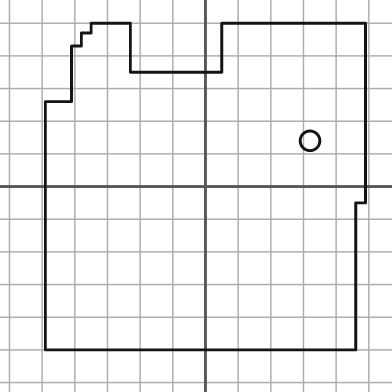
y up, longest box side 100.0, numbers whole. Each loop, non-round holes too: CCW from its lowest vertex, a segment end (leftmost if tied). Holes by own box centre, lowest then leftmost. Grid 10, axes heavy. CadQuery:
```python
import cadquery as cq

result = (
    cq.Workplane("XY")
    .moveTo(-49.0, -50.0)
    .lineTo(46.0, -50.0)
    .lineTo(46.0, -5.0)
    .lineTo(49.0, -5.0)
    .lineTo(49.0, 50.0)
    .lineTo(5.0, 50.0)
    .lineTo(5.0, 35.0)
    .lineTo(-23.0, 35.0)
    .lineTo(-23.0, 50.0)
    .lineTo(-35.0, 50.0)
    .lineTo(-35.0, 47.0)
    .lineTo(-38.0, 47.0)
    .lineTo(-38.0, 43.0)
    .lineTo(-41.0, 43.0)
    .lineTo(-41.0, 26.0)
    .lineTo(-49.0, 26.0)
    .close()
    .moveTo(32.0, 14.0)
    .circle(3.0)
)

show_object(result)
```